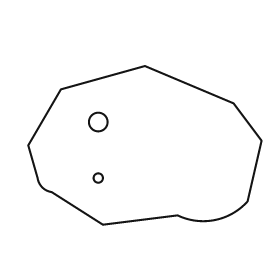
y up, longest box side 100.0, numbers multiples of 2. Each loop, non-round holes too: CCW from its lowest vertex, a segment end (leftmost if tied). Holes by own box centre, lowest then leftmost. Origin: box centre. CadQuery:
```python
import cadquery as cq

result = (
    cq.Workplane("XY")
    .moveTo(-18.0, -34.0)
    .lineTo(14.0, -30.0)
    .threePointArc((30.0, -32.0), (44.0, -24.0))
    .lineTo(50.0, 2.0)
    .lineTo(38.0, 18.0)
    .lineTo(0.0, 34.0)
    .lineTo(-36.0, 24.0)
    .lineTo(-50.0, 0.0)
    .lineTo(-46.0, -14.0)
    .threePointArc((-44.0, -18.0), (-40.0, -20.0))
    .close()
    .moveTo(-20.0, -14.0)
    .circle(2.0)
    .moveTo(-20.0, 10.0)
    .circle(4.0)
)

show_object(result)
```